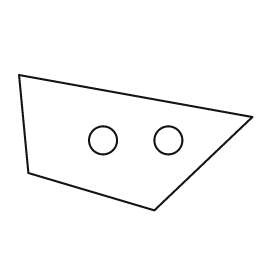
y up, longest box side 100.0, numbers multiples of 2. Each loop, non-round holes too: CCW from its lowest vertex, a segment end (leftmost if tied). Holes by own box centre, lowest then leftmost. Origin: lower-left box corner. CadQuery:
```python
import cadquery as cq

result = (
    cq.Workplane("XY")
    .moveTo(58.0, 0.0)
    .lineTo(100.0, 40.0)
    .lineTo(0.0, 58.0)
    .lineTo(4.0, 16.0)
    .close()
    .moveTo(36.0, 30.0)
    .circle(6.0)
    .moveTo(64.0, 30.0)
    .circle(6.0)
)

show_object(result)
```